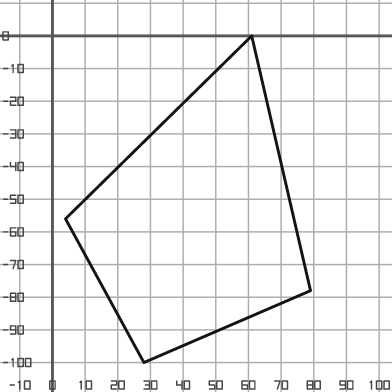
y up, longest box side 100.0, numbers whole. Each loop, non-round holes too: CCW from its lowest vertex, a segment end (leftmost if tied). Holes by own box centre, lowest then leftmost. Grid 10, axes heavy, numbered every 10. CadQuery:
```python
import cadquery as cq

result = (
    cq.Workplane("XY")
    .moveTo(28.0, -100.0)
    .lineTo(79.0, -78.0)
    .lineTo(61.0, 0.0)
    .lineTo(4.0, -56.0)
    .close()
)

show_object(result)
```